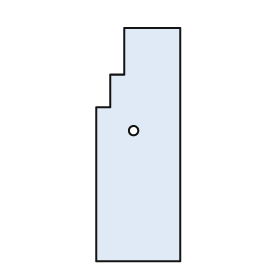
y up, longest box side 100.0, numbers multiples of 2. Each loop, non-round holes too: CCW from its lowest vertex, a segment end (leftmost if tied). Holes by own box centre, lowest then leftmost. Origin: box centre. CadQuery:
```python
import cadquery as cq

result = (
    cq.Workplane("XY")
    .moveTo(-18.0, -50.0)
    .lineTo(18.0, -50.0)
    .lineTo(18.0, 50.0)
    .lineTo(-6.0, 50.0)
    .lineTo(-6.0, 30.0)
    .lineTo(-12.0, 30.0)
    .lineTo(-12.0, 16.0)
    .lineTo(-18.0, 16.0)
    .close()
    .moveTo(-2.0, 6.0)
    .circle(2.0)
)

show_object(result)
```